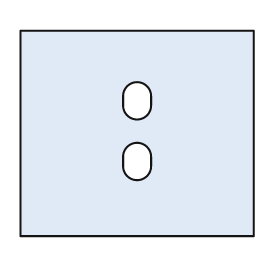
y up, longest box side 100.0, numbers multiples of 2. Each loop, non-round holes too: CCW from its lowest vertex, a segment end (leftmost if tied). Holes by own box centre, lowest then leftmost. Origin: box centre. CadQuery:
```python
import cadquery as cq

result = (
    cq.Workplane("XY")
    .moveTo(-50.0, -44.0)
    .lineTo(50.0, -44.0)
    .lineTo(50.0, 44.0)
    .lineTo(-50.0, 44.0)
    .close()
    .moveTo(-6.0, -14.0)
    .threePointArc((0.0, -20.0), (6.0, -14.0))
    .lineTo(6.0, -10.0)
    .threePointArc((0.0, -4.0), (-6.0, -10.0))
    .close()
    .moveTo(-6.0, 12.0)
    .threePointArc((0.0, 6.0), (6.0, 12.0))
    .lineTo(6.0, 16.0)
    .threePointArc((0.0, 22.0), (-6.0, 16.0))
    .close()
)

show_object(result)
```